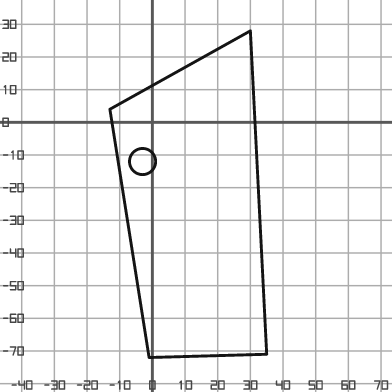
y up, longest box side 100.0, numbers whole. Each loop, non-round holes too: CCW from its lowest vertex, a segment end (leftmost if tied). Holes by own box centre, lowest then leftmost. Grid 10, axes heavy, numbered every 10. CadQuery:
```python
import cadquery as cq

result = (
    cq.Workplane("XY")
    .moveTo(-1.0, -72.0)
    .lineTo(35.0, -71.0)
    .lineTo(30.0, 28.0)
    .lineTo(-13.0, 4.0)
    .close()
    .moveTo(-3.0, -12.0)
    .circle(4.0)
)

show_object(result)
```